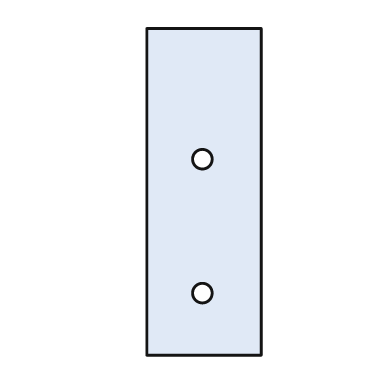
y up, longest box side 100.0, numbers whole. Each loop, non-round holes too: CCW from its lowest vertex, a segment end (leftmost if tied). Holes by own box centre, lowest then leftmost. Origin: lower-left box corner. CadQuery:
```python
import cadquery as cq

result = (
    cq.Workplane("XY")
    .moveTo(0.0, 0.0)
    .lineTo(35.0, 0.0)
    .lineTo(35.0, 100.0)
    .lineTo(0.0, 100.0)
    .close()
    .moveTo(17.0, 19.0)
    .circle(3.0)
    .moveTo(17.0, 60.0)
    .circle(3.0)
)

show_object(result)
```